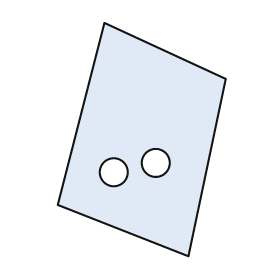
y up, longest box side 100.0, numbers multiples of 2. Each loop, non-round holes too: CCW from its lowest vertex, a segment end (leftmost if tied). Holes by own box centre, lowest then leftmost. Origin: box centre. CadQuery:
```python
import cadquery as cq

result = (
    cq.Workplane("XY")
    .moveTo(20.0, -50.0)
    .lineTo(36.0, 26.0)
    .lineTo(-16.0, 50.0)
    .lineTo(-36.0, -28.0)
    .close()
    .moveTo(-12.0, -14.0)
    .circle(6.0)
    .moveTo(6.0, -10.0)
    .circle(6.0)
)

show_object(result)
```